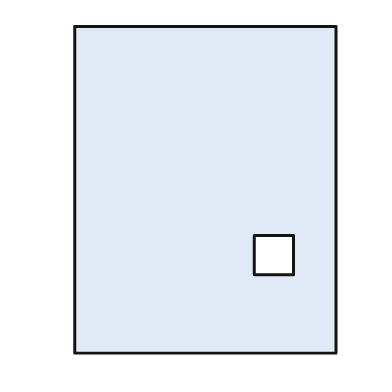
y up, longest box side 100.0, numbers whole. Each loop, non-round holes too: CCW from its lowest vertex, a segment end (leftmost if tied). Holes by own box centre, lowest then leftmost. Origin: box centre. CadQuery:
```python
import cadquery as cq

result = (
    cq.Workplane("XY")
    .moveTo(-40.0, -50.0)
    .lineTo(40.0, -50.0)
    .lineTo(40.0, 50.0)
    .lineTo(-40.0, 50.0)
    .close()
    .moveTo(15.0, -26.0)
    .lineTo(27.0, -26.0)
    .lineTo(27.0, -14.0)
    .lineTo(15.0, -14.0)
    .close()
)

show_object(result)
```